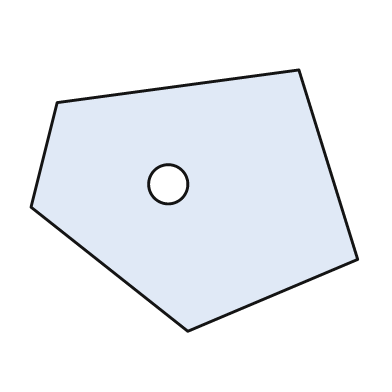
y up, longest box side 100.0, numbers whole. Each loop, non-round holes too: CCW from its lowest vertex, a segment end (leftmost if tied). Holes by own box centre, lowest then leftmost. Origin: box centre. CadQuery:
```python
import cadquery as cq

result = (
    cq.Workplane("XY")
    .moveTo(-2.0, -40.0)
    .lineTo(50.0, -18.0)
    .lineTo(32.0, 40.0)
    .lineTo(-42.0, 30.0)
    .lineTo(-50.0, -2.0)
    .close()
    .moveTo(-8.0, 5.0)
    .circle(6.0)
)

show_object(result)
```